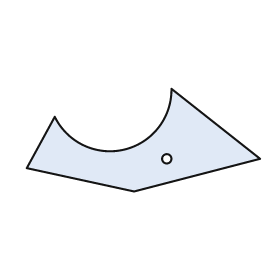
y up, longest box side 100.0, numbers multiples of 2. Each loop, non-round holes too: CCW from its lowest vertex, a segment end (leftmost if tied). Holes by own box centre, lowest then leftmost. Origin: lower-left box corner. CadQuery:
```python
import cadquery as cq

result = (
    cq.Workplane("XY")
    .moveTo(46.0, 0.0)
    .lineTo(100.0, 14.0)
    .lineTo(62.0, 44.0)
    .threePointArc((42.0, 18.0), (12.0, 32.0))
    .lineTo(0.0, 10.0)
    .close()
    .moveTo(60.0, 14.0)
    .circle(2.0)
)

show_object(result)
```